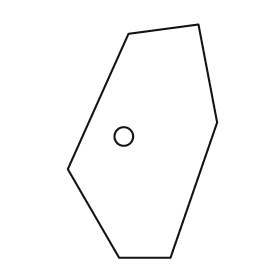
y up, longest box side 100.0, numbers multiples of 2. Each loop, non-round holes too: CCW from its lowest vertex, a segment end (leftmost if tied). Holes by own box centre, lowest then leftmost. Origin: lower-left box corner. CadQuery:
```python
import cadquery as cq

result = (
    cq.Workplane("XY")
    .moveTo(22.0, 0.0)
    .lineTo(44.0, 0.0)
    .lineTo(64.0, 58.0)
    .lineTo(56.0, 100.0)
    .lineTo(26.0, 96.0)
    .lineTo(0.0, 38.0)
    .close()
    .moveTo(24.0, 52.0)
    .circle(4.0)
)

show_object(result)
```